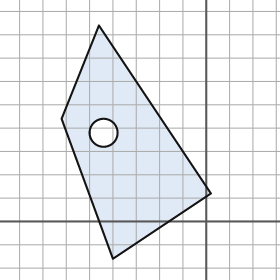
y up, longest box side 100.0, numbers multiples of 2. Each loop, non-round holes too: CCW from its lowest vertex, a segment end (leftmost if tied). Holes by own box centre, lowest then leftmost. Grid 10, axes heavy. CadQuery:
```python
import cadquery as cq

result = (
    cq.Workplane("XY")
    .moveTo(-40.0, -16.0)
    .lineTo(2.0, 12.0)
    .lineTo(-46.0, 84.0)
    .lineTo(-62.0, 44.0)
    .close()
    .moveTo(-44.0, 38.0)
    .circle(6.0)
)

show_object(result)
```